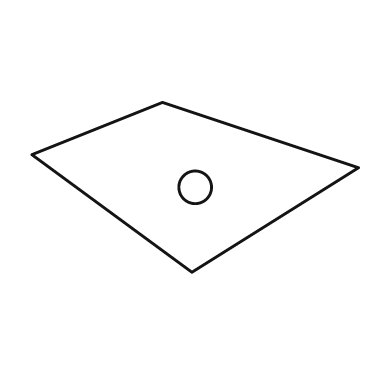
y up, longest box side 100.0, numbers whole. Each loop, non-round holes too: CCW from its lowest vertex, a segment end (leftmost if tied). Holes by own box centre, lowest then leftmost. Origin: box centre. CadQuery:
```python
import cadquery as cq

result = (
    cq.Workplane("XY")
    .moveTo(-1.0, -26.0)
    .lineTo(50.0, 6.0)
    .lineTo(-10.0, 26.0)
    .lineTo(-50.0, 10.0)
    .close()
    .moveTo(0.0, 0.0)
    .circle(5.0)
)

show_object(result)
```